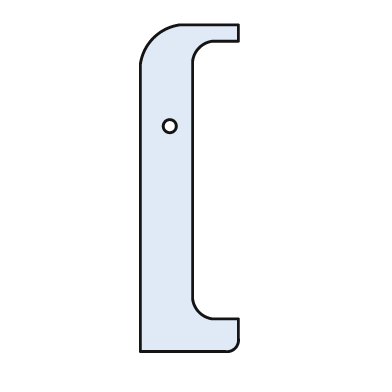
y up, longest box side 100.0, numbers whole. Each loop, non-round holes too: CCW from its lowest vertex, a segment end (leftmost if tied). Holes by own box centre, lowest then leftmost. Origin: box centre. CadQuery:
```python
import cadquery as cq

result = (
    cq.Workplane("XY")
    .moveTo(-15.0, -50.0)
    .lineTo(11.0, -50.0)
    .threePointArc((14.0, -49.0), (15.0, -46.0))
    .lineTo(15.0, -40.0)
    .lineTo(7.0, -40.0)
    .threePointArc((3.0, -38.0), (1.0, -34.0))
    .lineTo(1.0, 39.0)
    .threePointArc((3.0, 43.0), (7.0, 45.0))
    .lineTo(15.0, 45.0)
    .lineTo(15.0, 50.0)
    .lineTo(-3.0, 50.0)
    .threePointArc((-11.0, 46.0), (-15.0, 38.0))
    .close()
    .moveTo(-6.0, 19.0)
    .circle(2.0)
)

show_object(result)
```